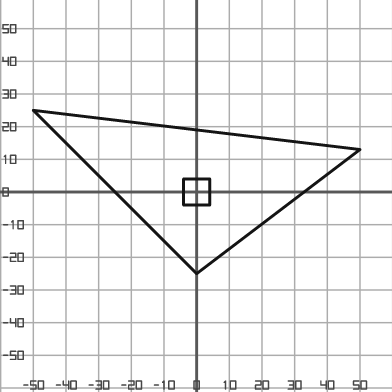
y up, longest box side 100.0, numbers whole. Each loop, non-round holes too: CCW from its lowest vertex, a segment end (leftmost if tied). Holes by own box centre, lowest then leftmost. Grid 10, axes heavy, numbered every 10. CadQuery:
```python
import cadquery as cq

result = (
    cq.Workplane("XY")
    .moveTo(0.0, -25.0)
    .lineTo(50.0, 13.0)
    .lineTo(-50.0, 25.0)
    .close()
    .moveTo(-4.0, -4.0)
    .lineTo(4.0, -4.0)
    .lineTo(4.0, 4.0)
    .lineTo(-4.0, 4.0)
    .close()
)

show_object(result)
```